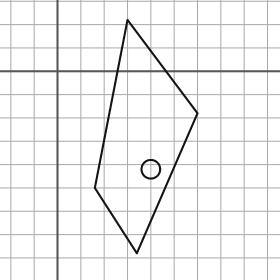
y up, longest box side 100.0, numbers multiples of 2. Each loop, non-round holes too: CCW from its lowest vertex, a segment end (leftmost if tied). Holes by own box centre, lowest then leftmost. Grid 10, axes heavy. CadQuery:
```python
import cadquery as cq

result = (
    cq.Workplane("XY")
    .moveTo(34.0, -78.0)
    .lineTo(60.0, -18.0)
    .lineTo(30.0, 22.0)
    .lineTo(16.0, -50.0)
    .close()
    .moveTo(40.0, -42.0)
    .circle(4.0)
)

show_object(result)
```